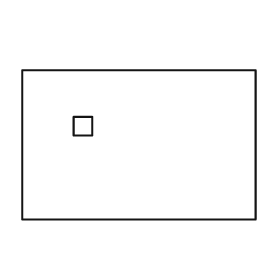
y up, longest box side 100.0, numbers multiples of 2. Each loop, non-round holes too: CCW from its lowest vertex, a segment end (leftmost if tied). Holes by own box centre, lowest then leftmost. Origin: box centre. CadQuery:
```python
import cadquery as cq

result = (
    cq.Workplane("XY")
    .moveTo(-50.0, -32.0)
    .lineTo(50.0, -32.0)
    .lineTo(50.0, 32.0)
    .lineTo(-50.0, 32.0)
    .close()
    .moveTo(-28.0, 4.0)
    .lineTo(-20.0, 4.0)
    .lineTo(-20.0, 12.0)
    .lineTo(-28.0, 12.0)
    .close()
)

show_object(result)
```